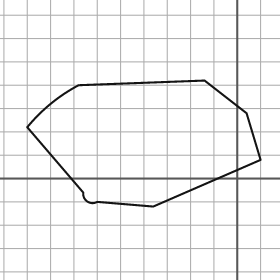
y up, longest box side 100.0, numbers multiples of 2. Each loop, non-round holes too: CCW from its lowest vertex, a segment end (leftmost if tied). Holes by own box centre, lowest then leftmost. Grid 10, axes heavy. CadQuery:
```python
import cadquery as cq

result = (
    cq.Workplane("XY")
    .moveTo(-36.0, -12.0)
    .lineTo(10.0, 8.0)
    .lineTo(4.0, 28.0)
    .lineTo(-14.0, 42.0)
    .lineTo(-68.0, 40.0)
    .threePointArc((-80.0, 32.0), (-90.0, 22.0))
    .lineTo(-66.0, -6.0)
    .threePointArc((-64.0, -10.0), (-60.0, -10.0))
    .close()
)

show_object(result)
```